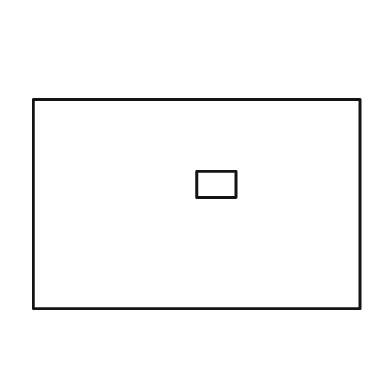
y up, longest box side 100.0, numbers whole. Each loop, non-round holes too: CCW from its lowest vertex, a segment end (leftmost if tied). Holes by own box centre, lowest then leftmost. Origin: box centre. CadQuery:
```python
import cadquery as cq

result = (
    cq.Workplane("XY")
    .moveTo(-50.0, -32.0)
    .lineTo(50.0, -32.0)
    .lineTo(50.0, 32.0)
    .lineTo(-50.0, 32.0)
    .close()
    .moveTo(0.0, 2.0)
    .lineTo(12.0, 2.0)
    .lineTo(12.0, 10.0)
    .lineTo(0.0, 10.0)
    .close()
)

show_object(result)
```